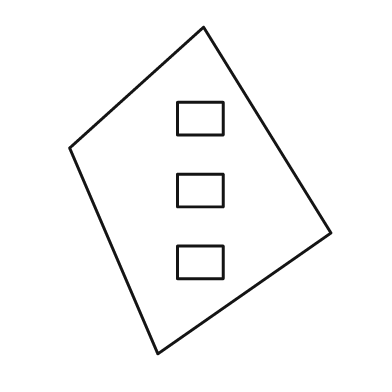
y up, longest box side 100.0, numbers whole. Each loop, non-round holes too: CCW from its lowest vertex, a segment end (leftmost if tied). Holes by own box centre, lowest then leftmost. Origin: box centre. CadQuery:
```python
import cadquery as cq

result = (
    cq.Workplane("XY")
    .moveTo(-13.0, -50.0)
    .lineTo(40.0, -13.0)
    .lineTo(1.0, 50.0)
    .lineTo(-40.0, 13.0)
    .close()
    .moveTo(-7.0, -27.0)
    .lineTo(7.0, -27.0)
    .lineTo(7.0, -17.0)
    .lineTo(-7.0, -17.0)
    .close()
    .moveTo(-7.0, -5.0)
    .lineTo(7.0, -5.0)
    .lineTo(7.0, 5.0)
    .lineTo(-7.0, 5.0)
    .close()
    .moveTo(-7.0, 17.0)
    .lineTo(7.0, 17.0)
    .lineTo(7.0, 27.0)
    .lineTo(-7.0, 27.0)
    .close()
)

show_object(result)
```